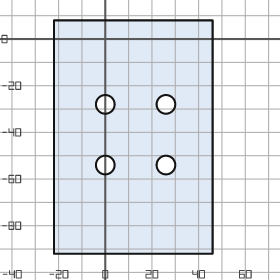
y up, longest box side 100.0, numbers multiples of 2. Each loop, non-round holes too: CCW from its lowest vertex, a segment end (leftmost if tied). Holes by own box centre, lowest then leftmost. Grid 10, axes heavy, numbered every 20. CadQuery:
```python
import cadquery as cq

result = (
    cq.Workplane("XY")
    .moveTo(-22.0, -92.0)
    .lineTo(46.0, -92.0)
    .lineTo(46.0, 8.0)
    .lineTo(-22.0, 8.0)
    .close()
    .moveTo(0.0, -54.0)
    .circle(4.0)
    .moveTo(26.0, -54.0)
    .circle(4.0)
    .moveTo(0.0, -28.0)
    .circle(4.0)
    .moveTo(26.0, -28.0)
    .circle(4.0)
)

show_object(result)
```